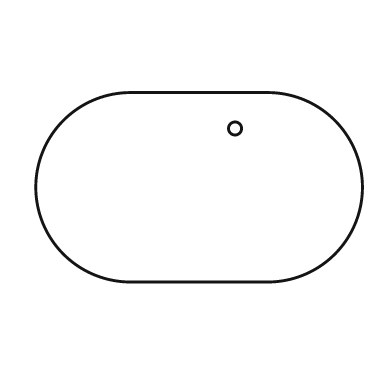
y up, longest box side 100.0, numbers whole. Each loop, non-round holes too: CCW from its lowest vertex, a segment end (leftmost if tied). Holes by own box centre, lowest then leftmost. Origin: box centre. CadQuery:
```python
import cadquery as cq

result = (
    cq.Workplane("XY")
    .moveTo(-21.0, -29.0)
    .lineTo(21.0, -29.0)
    .threePointArc((50.0, 0.0), (21.0, 29.0))
    .lineTo(-21.0, 29.0)
    .threePointArc((-50.0, 0.0), (-21.0, -29.0))
    .close()
    .moveTo(11.0, 18.0)
    .circle(2.0)
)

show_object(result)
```